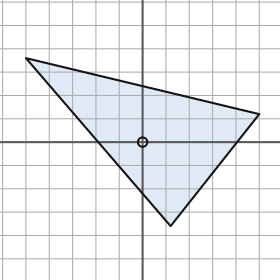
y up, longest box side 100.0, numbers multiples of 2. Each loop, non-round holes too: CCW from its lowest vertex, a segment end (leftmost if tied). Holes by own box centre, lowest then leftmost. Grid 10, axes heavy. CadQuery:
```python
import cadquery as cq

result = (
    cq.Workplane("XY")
    .moveTo(12.0, -36.0)
    .lineTo(50.0, 12.0)
    .lineTo(-50.0, 36.0)
    .close()
    .moveTo(0.0, 0.0)
    .circle(2.0)
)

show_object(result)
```